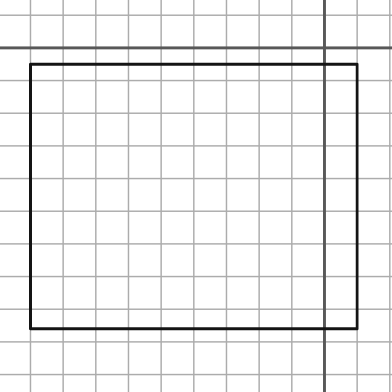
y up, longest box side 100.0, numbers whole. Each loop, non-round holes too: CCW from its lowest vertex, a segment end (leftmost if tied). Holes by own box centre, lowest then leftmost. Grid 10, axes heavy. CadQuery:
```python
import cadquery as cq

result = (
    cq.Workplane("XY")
    .moveTo(-90.0, -86.0)
    .lineTo(10.0, -86.0)
    .lineTo(10.0, -5.0)
    .lineTo(-90.0, -5.0)
    .close()
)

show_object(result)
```